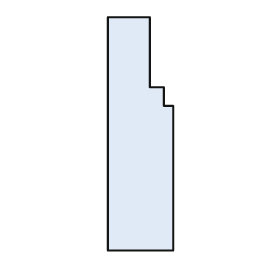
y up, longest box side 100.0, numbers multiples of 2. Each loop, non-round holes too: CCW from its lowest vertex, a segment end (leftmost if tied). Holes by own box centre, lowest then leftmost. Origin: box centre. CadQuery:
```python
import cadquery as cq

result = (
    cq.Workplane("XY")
    .moveTo(-14.0, -50.0)
    .lineTo(14.0, -50.0)
    .lineTo(14.0, 12.0)
    .lineTo(10.0, 12.0)
    .lineTo(10.0, 20.0)
    .lineTo(4.0, 20.0)
    .lineTo(4.0, 50.0)
    .lineTo(-14.0, 50.0)
    .close()
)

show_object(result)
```